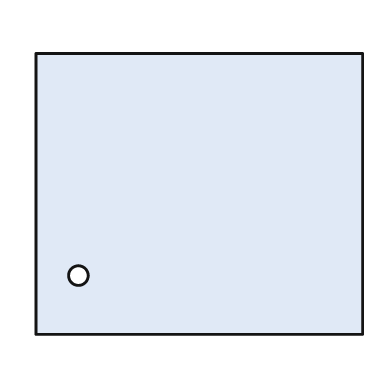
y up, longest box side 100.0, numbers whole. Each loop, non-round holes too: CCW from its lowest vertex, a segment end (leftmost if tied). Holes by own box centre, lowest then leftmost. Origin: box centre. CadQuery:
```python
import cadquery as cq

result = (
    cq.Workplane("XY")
    .moveTo(-50.0, -43.0)
    .lineTo(50.0, -43.0)
    .lineTo(50.0, 43.0)
    .lineTo(-50.0, 43.0)
    .close()
    .moveTo(-37.0, -25.0)
    .circle(3.0)
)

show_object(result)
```